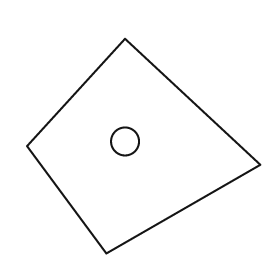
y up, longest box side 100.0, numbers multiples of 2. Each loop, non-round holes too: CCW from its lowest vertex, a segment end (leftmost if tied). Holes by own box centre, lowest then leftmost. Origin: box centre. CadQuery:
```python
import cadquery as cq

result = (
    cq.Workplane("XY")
    .moveTo(-16.0, -46.0)
    .lineTo(50.0, -8.0)
    .lineTo(-8.0, 46.0)
    .lineTo(-50.0, 0.0)
    .close()
    .moveTo(-8.0, 2.0)
    .circle(6.0)
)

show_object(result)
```